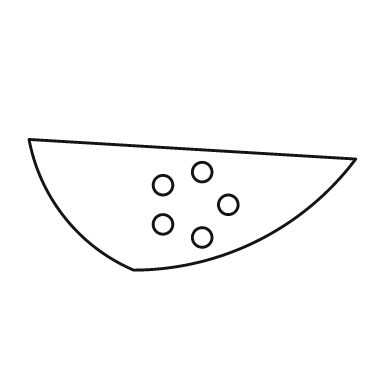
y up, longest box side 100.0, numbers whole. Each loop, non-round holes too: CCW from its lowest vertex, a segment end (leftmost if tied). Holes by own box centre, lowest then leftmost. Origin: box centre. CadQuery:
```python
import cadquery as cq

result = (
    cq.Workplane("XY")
    .moveTo(-18.0, -20.0)
    .threePointArc((20.0, -11.0), (50.0, 14.0))
    .lineTo(-50.0, 20.0)
    .threePointArc((-39.0, -4.0), (-18.0, -20.0))
    .close()
    .moveTo(3.0, -10.0)
    .circle(3.0)
    .moveTo(-9.0, -6.0)
    .circle(3.0)
    .moveTo(11.0, 0.0)
    .circle(3.0)
    .moveTo(-9.0, 6.0)
    .circle(3.0)
    .moveTo(3.0, 10.0)
    .circle(3.0)
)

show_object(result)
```